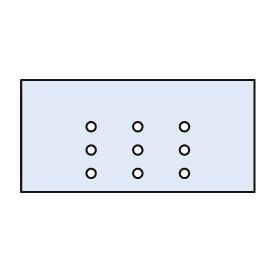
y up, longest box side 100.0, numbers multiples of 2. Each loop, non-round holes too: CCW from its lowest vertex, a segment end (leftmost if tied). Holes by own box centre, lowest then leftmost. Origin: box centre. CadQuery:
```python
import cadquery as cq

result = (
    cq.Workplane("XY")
    .moveTo(-50.0, -24.0)
    .lineTo(50.0, -24.0)
    .lineTo(50.0, 24.0)
    .lineTo(-50.0, 24.0)
    .close()
    .moveTo(-20.0, -16.0)
    .circle(2.0)
    .moveTo(0.0, -16.0)
    .circle(2.0)
    .moveTo(20.0, -16.0)
    .circle(2.0)
    .moveTo(-20.0, -6.0)
    .circle(2.0)
    .moveTo(0.0, -6.0)
    .circle(2.0)
    .moveTo(20.0, -6.0)
    .circle(2.0)
    .moveTo(-20.0, 4.0)
    .circle(2.0)
    .moveTo(0.0, 4.0)
    .circle(2.0)
    .moveTo(20.0, 4.0)
    .circle(2.0)
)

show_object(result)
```